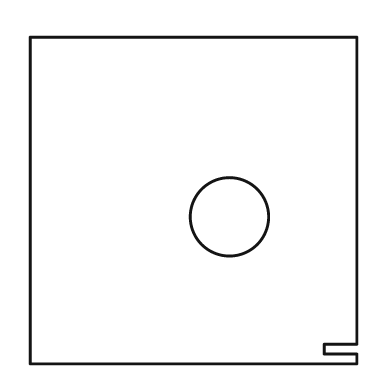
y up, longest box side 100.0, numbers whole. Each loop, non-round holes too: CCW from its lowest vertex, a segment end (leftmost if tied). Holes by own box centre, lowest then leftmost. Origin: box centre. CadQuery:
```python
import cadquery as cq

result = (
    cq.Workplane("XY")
    .moveTo(-50.0, -50.0)
    .lineTo(50.0, -50.0)
    .lineTo(50.0, -47.0)
    .lineTo(40.0, -47.0)
    .lineTo(40.0, -44.0)
    .lineTo(50.0, -44.0)
    .lineTo(50.0, 50.0)
    .lineTo(-50.0, 50.0)
    .close()
    .moveTo(11.0, -5.0)
    .circle(12.0)
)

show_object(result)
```